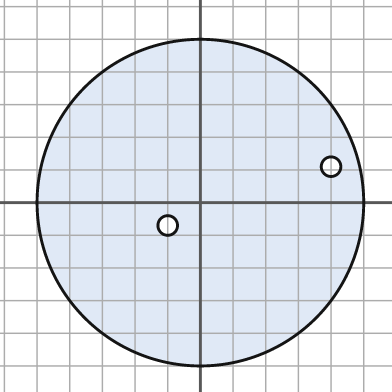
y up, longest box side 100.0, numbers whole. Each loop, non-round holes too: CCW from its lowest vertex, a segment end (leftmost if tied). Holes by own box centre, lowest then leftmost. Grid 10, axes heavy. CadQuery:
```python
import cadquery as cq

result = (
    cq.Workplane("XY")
    .moveTo(0.0, 0.0)
    .circle(50.0)
    .moveTo(-10.0, -7.0)
    .circle(3.0)
    .moveTo(40.0, 11.0)
    .circle(3.0)
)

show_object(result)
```